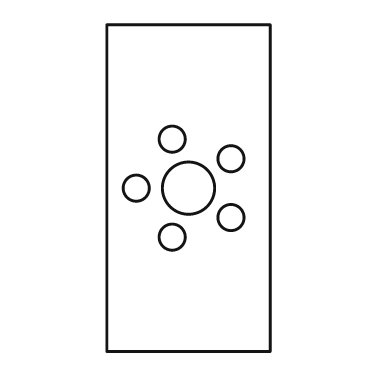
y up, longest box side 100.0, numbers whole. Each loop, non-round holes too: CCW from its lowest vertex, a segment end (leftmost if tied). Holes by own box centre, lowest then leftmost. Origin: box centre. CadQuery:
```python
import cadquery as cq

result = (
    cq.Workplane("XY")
    .moveTo(-25.0, -50.0)
    .lineTo(25.0, -50.0)
    .lineTo(25.0, 50.0)
    .lineTo(-25.0, 50.0)
    .close()
    .moveTo(-5.0, -15.0)
    .circle(4.0)
    .moveTo(13.0, -9.0)
    .circle(4.0)
    .moveTo(-16.0, 0.0)
    .circle(4.0)
    .moveTo(0.0, 0.0)
    .circle(8.0)
    .moveTo(13.0, 9.0)
    .circle(4.0)
    .moveTo(-5.0, 15.0)
    .circle(4.0)
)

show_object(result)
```